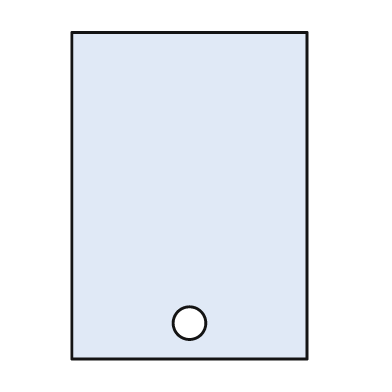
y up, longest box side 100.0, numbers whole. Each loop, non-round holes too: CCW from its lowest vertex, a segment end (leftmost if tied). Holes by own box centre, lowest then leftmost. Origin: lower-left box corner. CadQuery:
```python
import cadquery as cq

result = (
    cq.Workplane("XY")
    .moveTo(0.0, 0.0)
    .lineTo(72.0, 0.0)
    .lineTo(72.0, 100.0)
    .lineTo(0.0, 100.0)
    .close()
    .moveTo(36.0, 11.0)
    .circle(5.0)
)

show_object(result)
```